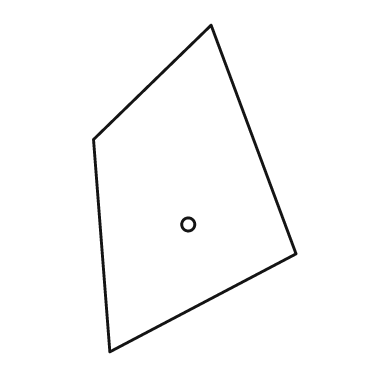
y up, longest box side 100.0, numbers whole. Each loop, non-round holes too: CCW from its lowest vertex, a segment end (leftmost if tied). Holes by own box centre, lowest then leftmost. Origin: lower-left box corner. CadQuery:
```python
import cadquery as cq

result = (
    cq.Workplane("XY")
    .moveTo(5.0, 0.0)
    .lineTo(62.0, 30.0)
    .lineTo(36.0, 100.0)
    .lineTo(0.0, 65.0)
    .close()
    .moveTo(29.0, 39.0)
    .circle(2.0)
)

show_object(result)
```